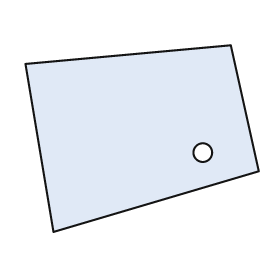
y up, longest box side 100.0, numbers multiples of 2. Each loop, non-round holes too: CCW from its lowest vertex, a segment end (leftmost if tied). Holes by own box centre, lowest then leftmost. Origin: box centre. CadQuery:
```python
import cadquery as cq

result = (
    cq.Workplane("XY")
    .moveTo(-38.0, -40.0)
    .lineTo(50.0, -14.0)
    .lineTo(38.0, 40.0)
    .lineTo(-50.0, 32.0)
    .close()
    .moveTo(26.0, -6.0)
    .circle(4.0)
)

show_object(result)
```